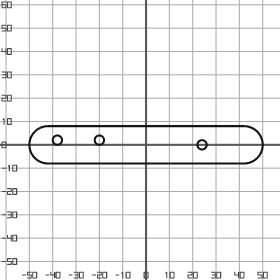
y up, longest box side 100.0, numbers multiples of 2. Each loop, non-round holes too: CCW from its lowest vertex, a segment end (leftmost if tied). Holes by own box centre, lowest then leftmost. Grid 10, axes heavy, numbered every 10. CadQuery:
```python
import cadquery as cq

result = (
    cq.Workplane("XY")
    .moveTo(-42.0, -8.0)
    .lineTo(42.0, -8.0)
    .threePointArc((50.0, 0.0), (42.0, 8.0))
    .lineTo(-42.0, 8.0)
    .threePointArc((-50.0, 0.0), (-42.0, -8.0))
    .close()
    .moveTo(24.0, 0.0)
    .circle(2.0)
    .moveTo(-38.0, 2.0)
    .circle(2.0)
    .moveTo(-20.0, 2.0)
    .circle(2.0)
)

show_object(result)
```